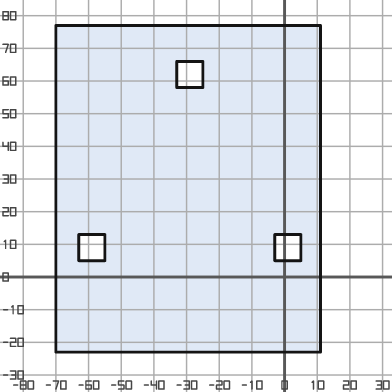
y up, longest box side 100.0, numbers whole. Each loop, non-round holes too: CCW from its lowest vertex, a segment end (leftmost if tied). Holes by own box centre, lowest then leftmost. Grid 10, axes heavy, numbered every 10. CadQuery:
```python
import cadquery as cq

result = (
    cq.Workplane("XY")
    .moveTo(-70.0, -23.0)
    .lineTo(11.0, -23.0)
    .lineTo(11.0, 77.0)
    .lineTo(-70.0, 77.0)
    .close()
    .moveTo(-63.0, 5.0)
    .lineTo(-55.0, 5.0)
    .lineTo(-55.0, 13.0)
    .lineTo(-63.0, 13.0)
    .close()
    .moveTo(-3.0, 5.0)
    .lineTo(5.0, 5.0)
    .lineTo(5.0, 13.0)
    .lineTo(-3.0, 13.0)
    .close()
    .moveTo(-33.0, 58.0)
    .lineTo(-25.0, 58.0)
    .lineTo(-25.0, 66.0)
    .lineTo(-33.0, 66.0)
    .close()
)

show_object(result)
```